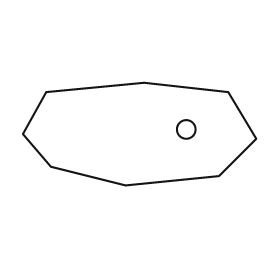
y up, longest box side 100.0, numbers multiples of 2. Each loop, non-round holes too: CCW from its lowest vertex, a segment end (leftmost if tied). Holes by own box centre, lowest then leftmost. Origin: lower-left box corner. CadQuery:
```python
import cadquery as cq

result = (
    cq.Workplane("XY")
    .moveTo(44.0, 0.0)
    .lineTo(84.0, 4.0)
    .lineTo(100.0, 20.0)
    .lineTo(88.0, 40.0)
    .lineTo(52.0, 44.0)
    .lineTo(10.0, 40.0)
    .lineTo(0.0, 22.0)
    .lineTo(12.0, 8.0)
    .close()
    .moveTo(70.0, 24.0)
    .circle(4.0)
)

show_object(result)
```